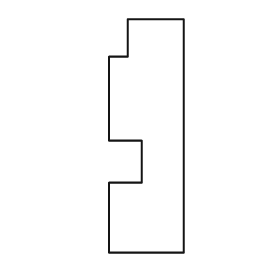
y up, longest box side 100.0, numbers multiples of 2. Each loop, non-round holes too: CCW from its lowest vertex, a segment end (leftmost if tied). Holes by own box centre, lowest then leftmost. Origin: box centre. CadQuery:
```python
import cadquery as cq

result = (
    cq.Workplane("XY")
    .moveTo(-16.0, -50.0)
    .lineTo(16.0, -50.0)
    .lineTo(16.0, 50.0)
    .lineTo(-8.0, 50.0)
    .lineTo(-8.0, 34.0)
    .lineTo(-16.0, 34.0)
    .lineTo(-16.0, -2.0)
    .lineTo(-2.0, -2.0)
    .lineTo(-2.0, -20.0)
    .lineTo(-16.0, -20.0)
    .close()
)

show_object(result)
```